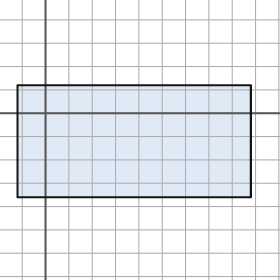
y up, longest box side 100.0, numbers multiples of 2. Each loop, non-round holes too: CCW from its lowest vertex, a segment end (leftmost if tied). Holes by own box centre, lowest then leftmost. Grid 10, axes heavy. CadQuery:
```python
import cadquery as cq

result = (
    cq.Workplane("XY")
    .moveTo(-12.0, -36.0)
    .lineTo(88.0, -36.0)
    .lineTo(88.0, 12.0)
    .lineTo(-12.0, 12.0)
    .close()
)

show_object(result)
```